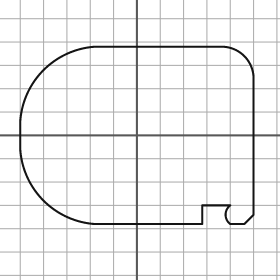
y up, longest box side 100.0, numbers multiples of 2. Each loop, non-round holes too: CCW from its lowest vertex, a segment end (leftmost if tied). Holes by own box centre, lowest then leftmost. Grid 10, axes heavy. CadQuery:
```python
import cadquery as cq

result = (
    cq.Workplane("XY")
    .moveTo(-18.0, -38.0)
    .lineTo(28.0, -38.0)
    .lineTo(28.0, -30.0)
    .lineTo(40.0, -30.0)
    .threePointArc((38.0, -34.0), (40.0, -38.0))
    .lineTo(46.0, -38.0)
    .lineTo(50.0, -34.0)
    .lineTo(50.0, 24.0)
    .threePointArc((46.0, 34.0), (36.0, 38.0))
    .lineTo(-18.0, 38.0)
    .threePointArc((-40.0, 28.0), (-50.0, 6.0))
    .lineTo(-50.0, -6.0)
    .threePointArc((-40.0, -28.0), (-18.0, -38.0))
    .close()
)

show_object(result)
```